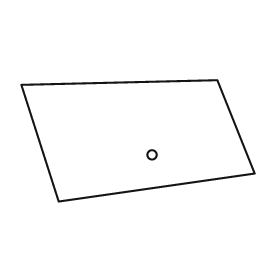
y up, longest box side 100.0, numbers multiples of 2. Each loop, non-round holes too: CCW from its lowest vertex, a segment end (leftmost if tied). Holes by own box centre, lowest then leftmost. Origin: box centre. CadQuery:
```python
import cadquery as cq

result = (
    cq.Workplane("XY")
    .moveTo(-34.0, -26.0)
    .lineTo(50.0, -14.0)
    .lineTo(34.0, 26.0)
    .lineTo(-50.0, 24.0)
    .close()
    .moveTo(6.0, -6.0)
    .circle(2.0)
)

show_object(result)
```